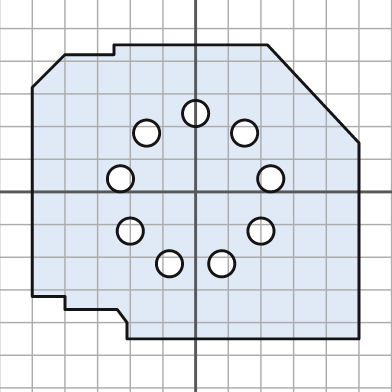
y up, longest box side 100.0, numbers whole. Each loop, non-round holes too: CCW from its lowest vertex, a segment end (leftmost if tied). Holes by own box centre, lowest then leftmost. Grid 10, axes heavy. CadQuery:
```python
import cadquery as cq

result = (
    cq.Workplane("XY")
    .moveTo(-21.0, -45.0)
    .lineTo(50.0, -45.0)
    .lineTo(50.0, 15.0)
    .lineTo(22.0, 45.0)
    .lineTo(-25.0, 45.0)
    .lineTo(-25.0, 42.0)
    .lineTo(-40.0, 42.0)
    .lineTo(-50.0, 32.0)
    .lineTo(-50.0, -32.0)
    .lineTo(-40.0, -32.0)
    .lineTo(-40.0, -36.0)
    .lineTo(-24.0, -36.0)
    .lineTo(-21.0, -40.0)
    .close()
    .moveTo(-8.0, -22.0)
    .circle(4.0)
    .moveTo(8.0, -22.0)
    .circle(4.0)
    .moveTo(-20.0, -12.0)
    .circle(4.0)
    .moveTo(20.0, -12.0)
    .circle(4.0)
    .moveTo(-23.0, 4.0)
    .circle(4.0)
    .moveTo(23.0, 4.0)
    .circle(4.0)
    .moveTo(-15.0, 18.0)
    .circle(4.0)
    .moveTo(15.0, 18.0)
    .circle(4.0)
    .moveTo(0.0, 24.0)
    .circle(4.0)
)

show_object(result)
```